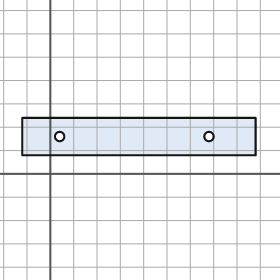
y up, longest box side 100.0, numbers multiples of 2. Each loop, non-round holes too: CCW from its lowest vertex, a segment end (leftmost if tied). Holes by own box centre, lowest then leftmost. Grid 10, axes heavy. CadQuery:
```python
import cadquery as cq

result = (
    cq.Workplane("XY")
    .moveTo(-12.0, 8.0)
    .lineTo(88.0, 8.0)
    .lineTo(88.0, 24.0)
    .lineTo(-12.0, 24.0)
    .close()
    .moveTo(4.0, 16.0)
    .circle(2.0)
    .moveTo(68.0, 16.0)
    .circle(2.0)
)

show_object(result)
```